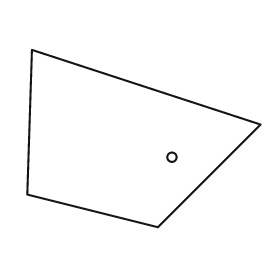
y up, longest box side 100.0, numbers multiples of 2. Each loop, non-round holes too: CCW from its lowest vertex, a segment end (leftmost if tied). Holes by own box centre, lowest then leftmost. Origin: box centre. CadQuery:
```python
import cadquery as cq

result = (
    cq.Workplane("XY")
    .moveTo(6.0, -38.0)
    .lineTo(50.0, 6.0)
    .lineTo(-48.0, 38.0)
    .lineTo(-50.0, -24.0)
    .close()
    .moveTo(12.0, -8.0)
    .circle(2.0)
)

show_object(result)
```